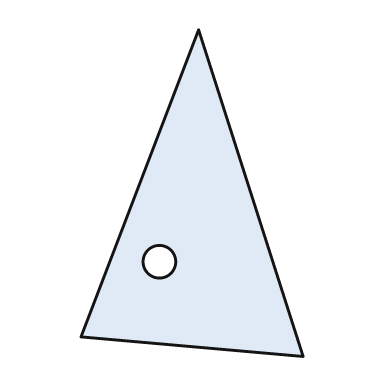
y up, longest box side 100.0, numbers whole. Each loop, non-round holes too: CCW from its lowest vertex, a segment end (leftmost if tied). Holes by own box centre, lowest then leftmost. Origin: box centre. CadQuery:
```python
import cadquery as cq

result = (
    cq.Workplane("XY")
    .moveTo(34.0, -50.0)
    .lineTo(2.0, 50.0)
    .lineTo(-34.0, -44.0)
    .close()
    .moveTo(-10.0, -21.0)
    .circle(5.0)
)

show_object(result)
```